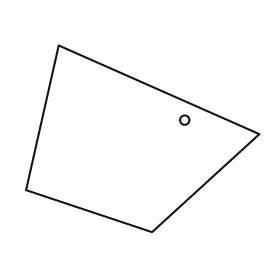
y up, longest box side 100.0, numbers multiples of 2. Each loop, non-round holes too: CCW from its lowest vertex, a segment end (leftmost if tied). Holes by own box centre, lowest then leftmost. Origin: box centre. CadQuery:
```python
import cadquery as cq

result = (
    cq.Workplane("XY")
    .moveTo(4.0, -40.0)
    .lineTo(50.0, 2.0)
    .lineTo(-36.0, 40.0)
    .lineTo(-50.0, -22.0)
    .close()
    .moveTo(18.0, 8.0)
    .circle(2.0)
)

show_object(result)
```